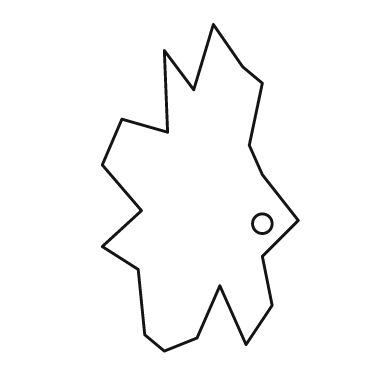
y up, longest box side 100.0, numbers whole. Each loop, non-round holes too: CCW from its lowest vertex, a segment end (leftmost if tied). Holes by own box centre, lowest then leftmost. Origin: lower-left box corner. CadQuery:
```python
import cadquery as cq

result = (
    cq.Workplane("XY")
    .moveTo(19.0, 0.0)
    .lineTo(29.0, 4.0)
    .lineTo(36.0, 20.0)
    .lineTo(44.0, 2.0)
    .lineTo(52.0, 14.0)
    .lineTo(49.0, 29.0)
    .lineTo(60.0, 40.0)
    .lineTo(49.0, 54.0)
    .lineTo(45.0, 63.0)
    .lineTo(49.0, 82.0)
    .lineTo(43.0, 87.0)
    .lineTo(34.0, 100.0)
    .lineTo(28.0, 80.0)
    .lineTo(19.0, 92.0)
    .lineTo(20.0, 67.0)
    .lineTo(6.0, 71.0)
    .lineTo(0.0, 57.0)
    .lineTo(12.0, 43.0)
    .lineTo(0.0, 32.0)
    .lineTo(11.0, 25.0)
    .lineTo(13.0, 5.0)
    .close()
    .moveTo(49.0, 39.0)
    .circle(3.0)
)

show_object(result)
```